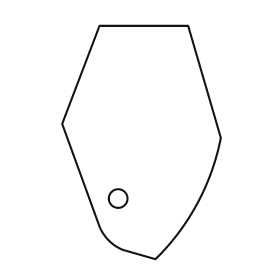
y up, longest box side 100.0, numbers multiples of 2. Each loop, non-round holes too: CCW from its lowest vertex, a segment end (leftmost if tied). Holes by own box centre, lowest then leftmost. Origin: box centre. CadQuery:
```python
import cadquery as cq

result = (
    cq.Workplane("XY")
    .moveTo(6.0, -50.0)
    .threePointArc((24.0, -26.0), (34.0, 2.0))
    .lineTo(20.0, 50.0)
    .lineTo(-18.0, 50.0)
    .lineTo(-34.0, 8.0)
    .lineTo(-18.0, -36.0)
    .threePointArc((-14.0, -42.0), (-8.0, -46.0))
    .close()
    .moveTo(-10.0, -24.0)
    .circle(4.0)
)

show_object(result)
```